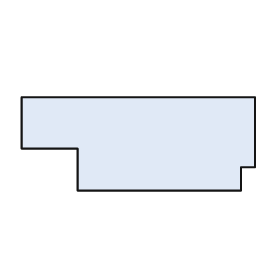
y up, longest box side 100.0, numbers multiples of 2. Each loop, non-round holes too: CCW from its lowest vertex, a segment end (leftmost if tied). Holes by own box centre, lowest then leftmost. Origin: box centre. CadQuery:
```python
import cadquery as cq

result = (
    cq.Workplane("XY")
    .moveTo(-26.0, -20.0)
    .lineTo(44.0, -20.0)
    .lineTo(44.0, -10.0)
    .lineTo(50.0, -10.0)
    .lineTo(50.0, 20.0)
    .lineTo(-50.0, 20.0)
    .lineTo(-50.0, -2.0)
    .lineTo(-26.0, -2.0)
    .close()
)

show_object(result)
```